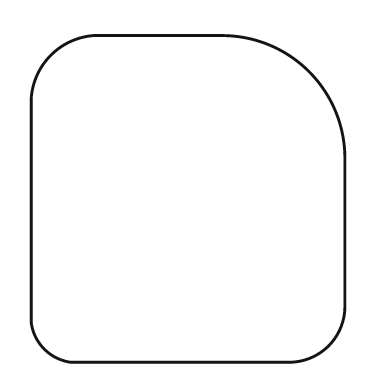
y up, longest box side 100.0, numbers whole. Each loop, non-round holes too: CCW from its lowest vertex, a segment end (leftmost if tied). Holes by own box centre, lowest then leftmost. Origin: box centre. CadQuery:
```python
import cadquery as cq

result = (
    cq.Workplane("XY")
    .moveTo(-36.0, -50.0)
    .lineTo(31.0, -50.0)
    .threePointArc((43.0, -45.0), (48.0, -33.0))
    .lineTo(48.0, 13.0)
    .threePointArc((37.0, 39.0), (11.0, 50.0))
    .lineTo(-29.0, 50.0)
    .threePointArc((-42.0, 44.0), (-48.0, 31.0))
    .lineTo(-48.0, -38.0)
    .threePointArc((-44.0, -46.0), (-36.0, -50.0))
    .close()
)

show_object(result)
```